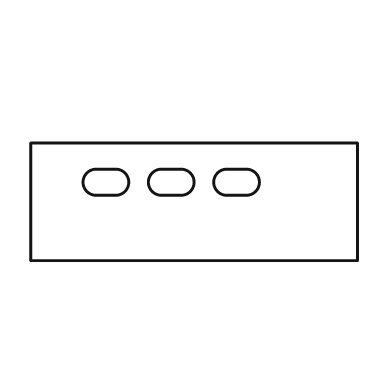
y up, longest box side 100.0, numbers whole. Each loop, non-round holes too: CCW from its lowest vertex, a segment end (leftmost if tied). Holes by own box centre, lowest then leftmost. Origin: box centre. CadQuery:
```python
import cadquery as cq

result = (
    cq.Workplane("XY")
    .moveTo(-50.0, -18.0)
    .lineTo(50.0, -18.0)
    .lineTo(50.0, 18.0)
    .lineTo(-50.0, 18.0)
    .close()
    .moveTo(-30.0, 2.0)
    .lineTo(-24.0, 2.0)
    .threePointArc((-20.0, 6.0), (-24.0, 10.0))
    .lineTo(-30.0, 10.0)
    .threePointArc((-34.0, 6.0), (-30.0, 2.0))
    .close()
    .moveTo(-10.0, 2.0)
    .lineTo(-4.0, 2.0)
    .threePointArc((0.0, 6.0), (-4.0, 10.0))
    .lineTo(-10.0, 10.0)
    .threePointArc((-14.0, 6.0), (-10.0, 2.0))
    .close()
    .moveTo(10.0, 2.0)
    .lineTo(16.0, 2.0)
    .threePointArc((20.0, 6.0), (16.0, 10.0))
    .lineTo(10.0, 10.0)
    .threePointArc((6.0, 6.0), (10.0, 2.0))
    .close()
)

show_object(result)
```